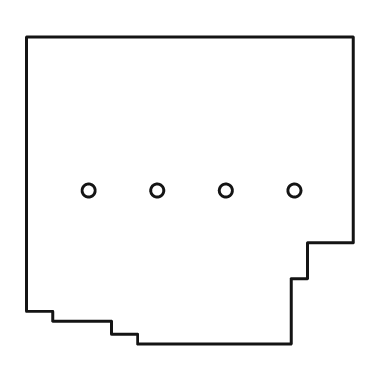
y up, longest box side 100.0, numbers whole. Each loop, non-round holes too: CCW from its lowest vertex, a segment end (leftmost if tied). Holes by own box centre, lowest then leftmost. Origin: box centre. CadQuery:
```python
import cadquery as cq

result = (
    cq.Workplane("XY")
    .moveTo(-16.0, -47.0)
    .lineTo(31.0, -47.0)
    .lineTo(31.0, -27.0)
    .lineTo(36.0, -27.0)
    .lineTo(36.0, -16.0)
    .lineTo(50.0, -16.0)
    .lineTo(50.0, 47.0)
    .lineTo(-50.0, 47.0)
    .lineTo(-50.0, -37.0)
    .lineTo(-42.0, -37.0)
    .lineTo(-42.0, -40.0)
    .lineTo(-24.0, -40.0)
    .lineTo(-24.0, -44.0)
    .lineTo(-16.0, -44.0)
    .close()
    .moveTo(-31.0, 0.0)
    .circle(2.0)
    .moveTo(-10.0, 0.0)
    .circle(2.0)
    .moveTo(11.0, 0.0)
    .circle(2.0)
    .moveTo(32.0, 0.0)
    .circle(2.0)
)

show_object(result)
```